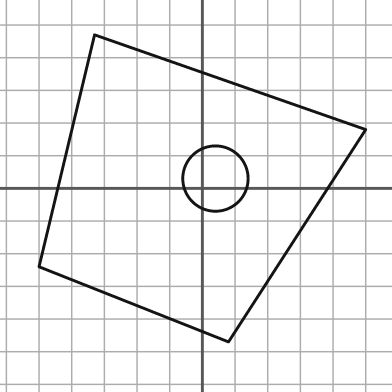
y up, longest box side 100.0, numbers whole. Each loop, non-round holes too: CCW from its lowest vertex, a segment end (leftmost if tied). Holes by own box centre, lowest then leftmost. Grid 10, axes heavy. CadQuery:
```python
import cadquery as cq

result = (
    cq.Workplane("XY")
    .moveTo(8.0, -47.0)
    .lineTo(50.0, 18.0)
    .lineTo(-33.0, 47.0)
    .lineTo(-50.0, -24.0)
    .close()
    .moveTo(4.0, 3.0)
    .circle(10.0)
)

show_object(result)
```